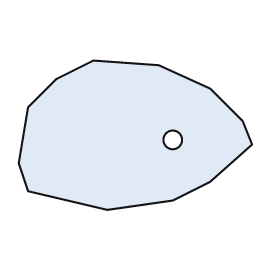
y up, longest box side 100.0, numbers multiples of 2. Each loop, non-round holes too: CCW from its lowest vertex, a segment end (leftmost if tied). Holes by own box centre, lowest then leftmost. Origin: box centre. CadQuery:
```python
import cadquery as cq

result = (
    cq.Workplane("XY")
    .moveTo(-12.0, -32.0)
    .lineTo(16.0, -28.0)
    .lineTo(32.0, -20.0)
    .lineTo(50.0, -4.0)
    .lineTo(46.0, 6.0)
    .lineTo(32.0, 20.0)
    .lineTo(10.0, 30.0)
    .lineTo(-18.0, 32.0)
    .lineTo(-34.0, 24.0)
    .lineTo(-46.0, 12.0)
    .lineTo(-50.0, -12.0)
    .lineTo(-46.0, -24.0)
    .close()
    .moveTo(16.0, -2.0)
    .circle(4.0)
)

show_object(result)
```